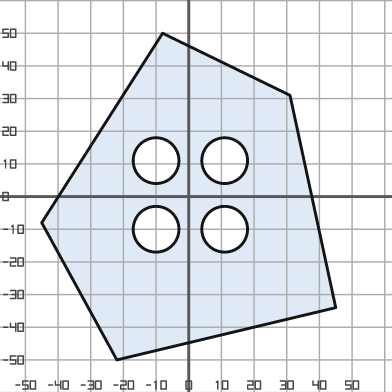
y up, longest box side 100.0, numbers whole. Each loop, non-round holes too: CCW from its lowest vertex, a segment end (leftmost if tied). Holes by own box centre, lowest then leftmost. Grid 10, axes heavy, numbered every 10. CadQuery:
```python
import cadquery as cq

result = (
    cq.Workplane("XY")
    .moveTo(-22.0, -50.0)
    .lineTo(45.0, -34.0)
    .lineTo(31.0, 31.0)
    .lineTo(-8.0, 50.0)
    .lineTo(-45.0, -8.0)
    .close()
    .moveTo(-10.0, -10.0)
    .circle(7.0)
    .moveTo(11.0, -10.0)
    .circle(7.0)
    .moveTo(-10.0, 11.0)
    .circle(7.0)
    .moveTo(11.0, 11.0)
    .circle(7.0)
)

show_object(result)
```